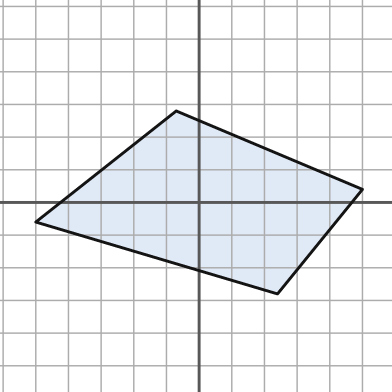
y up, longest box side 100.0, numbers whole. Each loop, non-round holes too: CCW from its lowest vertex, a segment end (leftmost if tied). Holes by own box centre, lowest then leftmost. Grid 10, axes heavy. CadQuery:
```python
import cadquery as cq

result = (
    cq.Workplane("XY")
    .moveTo(24.0, -28.0)
    .lineTo(50.0, 4.0)
    .lineTo(-7.0, 28.0)
    .lineTo(-50.0, -6.0)
    .close()
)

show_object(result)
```